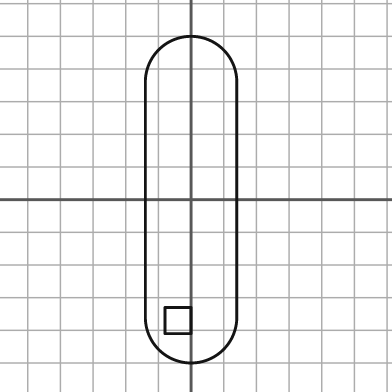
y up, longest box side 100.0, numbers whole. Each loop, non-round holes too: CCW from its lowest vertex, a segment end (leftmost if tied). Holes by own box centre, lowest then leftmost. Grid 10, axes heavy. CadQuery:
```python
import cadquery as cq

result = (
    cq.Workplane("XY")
    .moveTo(-14.0, -36.0)
    .threePointArc((0.0, -50.0), (14.0, -36.0))
    .lineTo(14.0, 36.0)
    .threePointArc((0.0, 50.0), (-14.0, 36.0))
    .close()
    .moveTo(-8.0, -41.0)
    .lineTo(0.0, -41.0)
    .lineTo(0.0, -33.0)
    .lineTo(-8.0, -33.0)
    .close()
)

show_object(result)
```